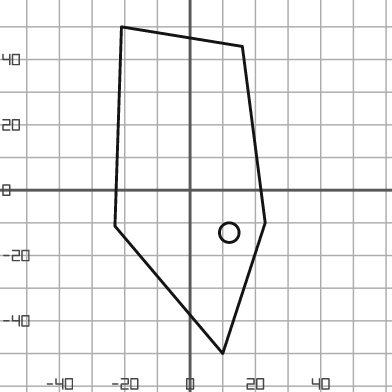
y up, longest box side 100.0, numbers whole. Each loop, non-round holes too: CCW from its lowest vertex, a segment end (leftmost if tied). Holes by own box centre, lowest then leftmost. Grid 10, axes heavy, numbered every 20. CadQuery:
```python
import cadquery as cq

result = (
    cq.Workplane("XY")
    .moveTo(10.0, -50.0)
    .lineTo(23.0, -10.0)
    .lineTo(16.0, 44.0)
    .lineTo(-21.0, 50.0)
    .lineTo(-23.0, -11.0)
    .close()
    .moveTo(12.0, -13.0)
    .circle(3.0)
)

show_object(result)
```